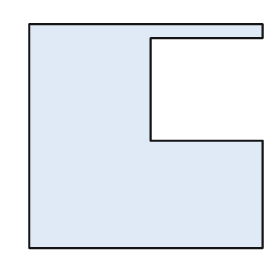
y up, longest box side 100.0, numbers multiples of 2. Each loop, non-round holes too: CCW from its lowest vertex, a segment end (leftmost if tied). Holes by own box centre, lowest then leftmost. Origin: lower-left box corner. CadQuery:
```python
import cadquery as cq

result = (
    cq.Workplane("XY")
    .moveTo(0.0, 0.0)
    .lineTo(100.0, 0.0)
    .lineTo(100.0, 46.0)
    .lineTo(52.0, 46.0)
    .lineTo(52.0, 90.0)
    .lineTo(100.0, 90.0)
    .lineTo(100.0, 96.0)
    .lineTo(0.0, 96.0)
    .close()
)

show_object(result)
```